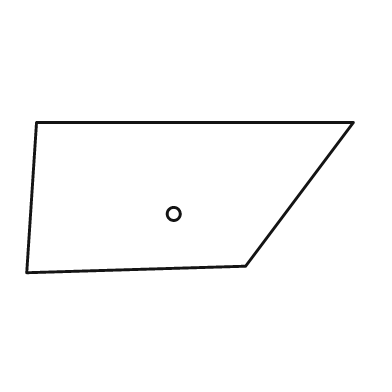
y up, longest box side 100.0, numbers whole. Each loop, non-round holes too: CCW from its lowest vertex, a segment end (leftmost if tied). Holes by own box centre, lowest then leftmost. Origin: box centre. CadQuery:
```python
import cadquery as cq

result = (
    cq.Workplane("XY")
    .moveTo(-50.0, -23.0)
    .lineTo(17.0, -21.0)
    .lineTo(50.0, 23.0)
    .lineTo(-47.0, 23.0)
    .close()
    .moveTo(-5.0, -5.0)
    .circle(2.0)
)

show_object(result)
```